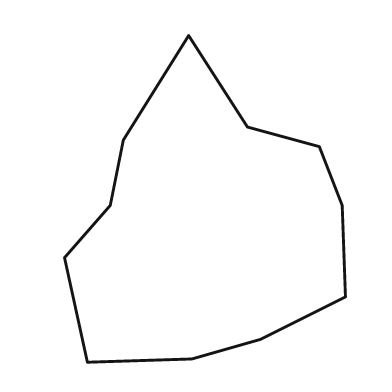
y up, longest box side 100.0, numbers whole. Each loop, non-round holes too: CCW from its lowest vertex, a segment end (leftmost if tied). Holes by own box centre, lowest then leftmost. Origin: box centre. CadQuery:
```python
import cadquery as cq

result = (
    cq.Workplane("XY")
    .moveTo(-36.0, -50.0)
    .lineTo(-4.0, -49.0)
    .lineTo(17.0, -43.0)
    .lineTo(43.0, -30.0)
    .lineTo(42.0, -2.0)
    .lineTo(35.0, 16.0)
    .lineTo(13.0, 22.0)
    .lineTo(-5.0, 50.0)
    .lineTo(-25.0, 18.0)
    .lineTo(-29.0, -2.0)
    .lineTo(-43.0, -18.0)
    .close()
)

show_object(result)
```